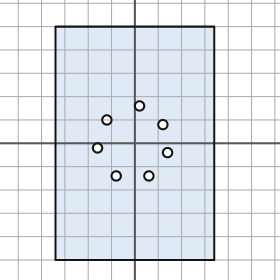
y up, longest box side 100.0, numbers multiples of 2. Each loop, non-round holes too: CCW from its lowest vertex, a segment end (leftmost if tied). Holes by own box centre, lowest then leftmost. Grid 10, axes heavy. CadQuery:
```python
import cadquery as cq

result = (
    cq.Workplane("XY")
    .moveTo(-34.0, -50.0)
    .lineTo(34.0, -50.0)
    .lineTo(34.0, 50.0)
    .lineTo(-34.0, 50.0)
    .close()
    .moveTo(-8.0, -14.0)
    .circle(2.0)
    .moveTo(6.0, -14.0)
    .circle(2.0)
    .moveTo(14.0, -4.0)
    .circle(2.0)
    .moveTo(-16.0, -2.0)
    .circle(2.0)
    .moveTo(12.0, 8.0)
    .circle(2.0)
    .moveTo(-12.0, 10.0)
    .circle(2.0)
    .moveTo(2.0, 16.0)
    .circle(2.0)
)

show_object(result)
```